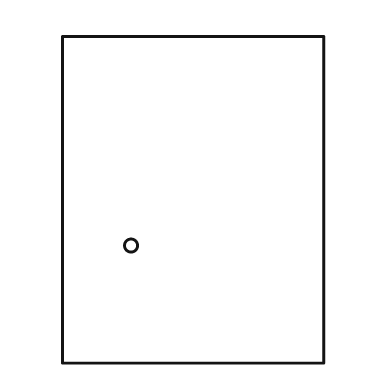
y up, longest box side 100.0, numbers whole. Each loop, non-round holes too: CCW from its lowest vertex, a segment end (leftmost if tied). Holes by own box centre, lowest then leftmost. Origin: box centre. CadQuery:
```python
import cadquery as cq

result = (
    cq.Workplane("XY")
    .moveTo(-40.0, -50.0)
    .lineTo(40.0, -50.0)
    .lineTo(40.0, 50.0)
    .lineTo(-40.0, 50.0)
    .close()
    .moveTo(-19.0, -14.0)
    .circle(2.0)
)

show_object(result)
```